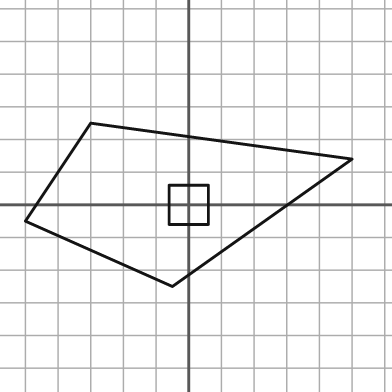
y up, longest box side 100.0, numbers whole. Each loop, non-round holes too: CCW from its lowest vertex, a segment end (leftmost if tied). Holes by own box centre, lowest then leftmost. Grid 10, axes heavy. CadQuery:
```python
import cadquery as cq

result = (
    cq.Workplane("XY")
    .moveTo(-5.0, -25.0)
    .lineTo(50.0, 14.0)
    .lineTo(-30.0, 25.0)
    .lineTo(-50.0, -5.0)
    .close()
    .moveTo(-6.0, -6.0)
    .lineTo(6.0, -6.0)
    .lineTo(6.0, 6.0)
    .lineTo(-6.0, 6.0)
    .close()
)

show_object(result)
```